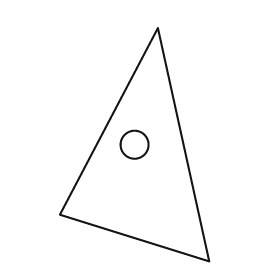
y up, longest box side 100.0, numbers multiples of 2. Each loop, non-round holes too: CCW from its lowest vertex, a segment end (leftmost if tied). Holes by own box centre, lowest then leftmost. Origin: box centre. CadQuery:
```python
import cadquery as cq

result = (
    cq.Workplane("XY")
    .moveTo(32.0, -50.0)
    .lineTo(10.0, 50.0)
    .lineTo(-32.0, -30.0)
    .close()
    .moveTo(0.0, 0.0)
    .circle(6.0)
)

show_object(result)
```